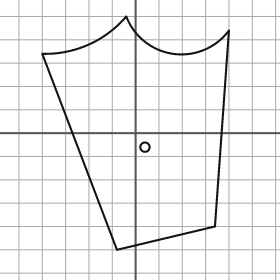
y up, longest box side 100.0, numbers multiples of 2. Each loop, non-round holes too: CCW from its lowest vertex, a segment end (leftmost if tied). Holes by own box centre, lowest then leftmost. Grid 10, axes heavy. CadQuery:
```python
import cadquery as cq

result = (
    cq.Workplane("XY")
    .moveTo(-8.0, -50.0)
    .lineTo(34.0, -40.0)
    .lineTo(40.0, 44.0)
    .threePointArc((16.0, 34.0), (-4.0, 50.0))
    .threePointArc((-20.0, 38.0), (-40.0, 34.0))
    .close()
    .moveTo(4.0, -6.0)
    .circle(2.0)
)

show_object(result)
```